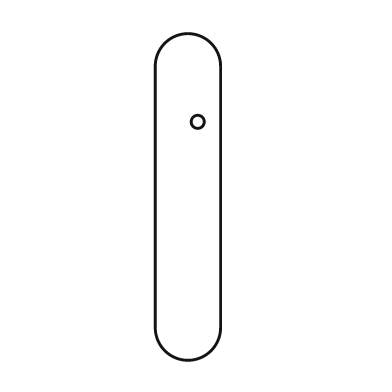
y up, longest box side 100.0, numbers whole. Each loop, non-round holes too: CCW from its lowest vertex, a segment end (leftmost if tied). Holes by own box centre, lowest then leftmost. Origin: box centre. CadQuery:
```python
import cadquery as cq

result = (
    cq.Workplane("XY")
    .moveTo(-10.0, -40.0)
    .threePointArc((0.0, -50.0), (10.0, -40.0))
    .lineTo(10.0, 40.0)
    .threePointArc((0.0, 50.0), (-10.0, 40.0))
    .close()
    .moveTo(3.0, 23.0)
    .circle(2.0)
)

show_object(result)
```